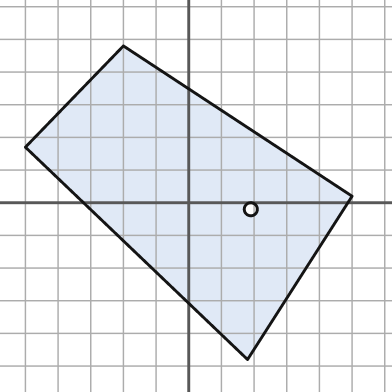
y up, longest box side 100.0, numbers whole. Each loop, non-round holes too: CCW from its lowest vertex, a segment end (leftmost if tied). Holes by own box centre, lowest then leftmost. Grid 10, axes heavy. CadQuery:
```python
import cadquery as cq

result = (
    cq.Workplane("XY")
    .moveTo(18.0, -48.0)
    .lineTo(50.0, 2.0)
    .lineTo(-20.0, 48.0)
    .lineTo(-50.0, 17.0)
    .close()
    .moveTo(19.0, -2.0)
    .circle(2.0)
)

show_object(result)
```